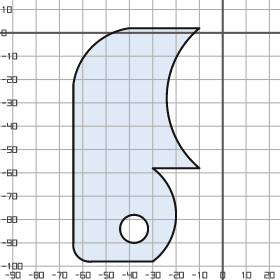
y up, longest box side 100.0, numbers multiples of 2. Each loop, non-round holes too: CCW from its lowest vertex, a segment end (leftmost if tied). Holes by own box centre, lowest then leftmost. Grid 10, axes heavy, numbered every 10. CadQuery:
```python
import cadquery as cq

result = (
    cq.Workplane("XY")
    .moveTo(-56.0, -98.0)
    .lineTo(-30.0, -98.0)
    .threePointArc((-20.0, -78.0), (-30.0, -58.0))
    .lineTo(-10.0, -58.0)
    .threePointArc((-24.0, -28.0), (-10.0, 2.0))
    .lineTo(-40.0, 2.0)
    .threePointArc((-56.0, -6.0), (-64.0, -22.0))
    .lineTo(-64.0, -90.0)
    .threePointArc((-62.0, -96.0), (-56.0, -98.0))
    .close()
    .moveTo(-38.0, -84.0)
    .circle(6.0)
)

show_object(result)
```